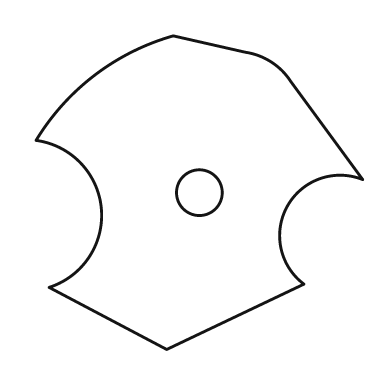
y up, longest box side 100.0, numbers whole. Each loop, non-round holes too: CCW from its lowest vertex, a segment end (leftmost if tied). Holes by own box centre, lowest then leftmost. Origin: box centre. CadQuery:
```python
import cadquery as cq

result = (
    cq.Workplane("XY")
    .moveTo(-10.0, -48.0)
    .lineTo(32.0, -28.0)
    .threePointArc((27.0, -4.0), (50.0, 4.0))
    .lineTo(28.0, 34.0)
    .threePointArc((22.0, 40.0), (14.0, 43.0))
    .lineTo(-8.0, 48.0)
    .threePointArc((-32.0, 36.0), (-50.0, 16.0))
    .threePointArc((-30.0, -5.0), (-46.0, -29.0))
    .close()
    .moveTo(0.0, 0.0)
    .circle(7.0)
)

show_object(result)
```